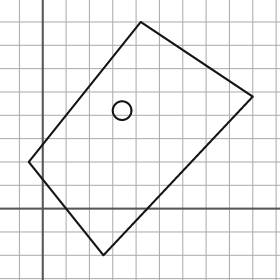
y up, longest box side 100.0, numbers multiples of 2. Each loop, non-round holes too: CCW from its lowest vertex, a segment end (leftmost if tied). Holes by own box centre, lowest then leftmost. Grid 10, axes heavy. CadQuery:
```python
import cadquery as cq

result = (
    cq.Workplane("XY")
    .moveTo(26.0, -20.0)
    .lineTo(90.0, 48.0)
    .lineTo(42.0, 80.0)
    .lineTo(-6.0, 20.0)
    .close()
    .moveTo(34.0, 42.0)
    .circle(4.0)
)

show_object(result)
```